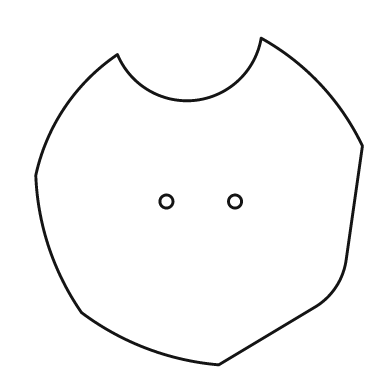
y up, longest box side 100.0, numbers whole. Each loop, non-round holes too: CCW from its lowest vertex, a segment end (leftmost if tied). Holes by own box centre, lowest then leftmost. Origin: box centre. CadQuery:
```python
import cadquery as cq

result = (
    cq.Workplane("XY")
    .moveTo(6.0, -50.0)
    .lineTo(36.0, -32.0)
    .threePointArc((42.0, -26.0), (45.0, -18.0))
    .lineTo(50.0, 17.0)
    .threePointArc((37.0, 36.0), (19.0, 50.0))
    .threePointArc((-1.0, 31.0), (-25.0, 45.0))
    .threePointArc((-41.0, 29.0), (-50.0, 8.0))
    .threePointArc((-46.0, -14.0), (-36.0, -34.0))
    .threePointArc((-16.0, -45.0), (6.0, -50.0))
    .close()
    .moveTo(-10.0, 0.0)
    .circle(2.0)
    .moveTo(11.0, 0.0)
    .circle(2.0)
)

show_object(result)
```